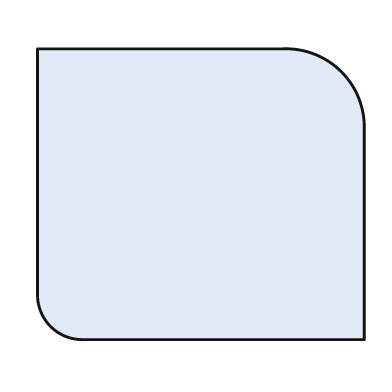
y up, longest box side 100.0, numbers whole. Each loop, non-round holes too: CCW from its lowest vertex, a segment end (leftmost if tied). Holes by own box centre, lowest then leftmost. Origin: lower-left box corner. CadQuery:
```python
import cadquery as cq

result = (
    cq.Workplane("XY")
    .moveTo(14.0, 0.0)
    .lineTo(100.0, 0.0)
    .lineTo(100.0, 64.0)
    .threePointArc((93.0, 82.0), (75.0, 89.0))
    .lineTo(0.0, 89.0)
    .lineTo(0.0, 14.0)
    .threePointArc((4.0, 4.0), (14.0, 0.0))
    .close()
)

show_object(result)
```